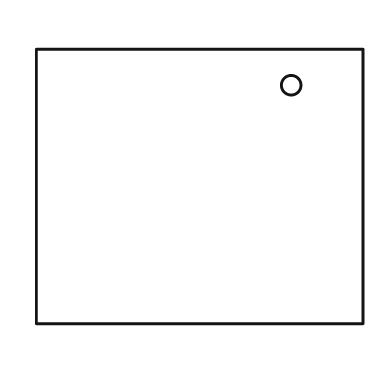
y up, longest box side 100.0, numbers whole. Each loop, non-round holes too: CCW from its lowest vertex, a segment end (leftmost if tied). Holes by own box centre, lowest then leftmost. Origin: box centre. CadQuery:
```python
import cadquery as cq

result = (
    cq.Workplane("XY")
    .moveTo(-50.0, -42.0)
    .lineTo(50.0, -42.0)
    .lineTo(50.0, 42.0)
    .lineTo(-50.0, 42.0)
    .close()
    .moveTo(28.0, 31.0)
    .circle(3.0)
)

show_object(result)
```